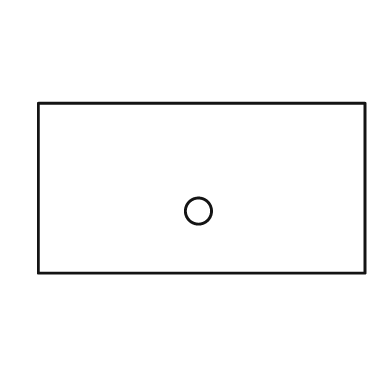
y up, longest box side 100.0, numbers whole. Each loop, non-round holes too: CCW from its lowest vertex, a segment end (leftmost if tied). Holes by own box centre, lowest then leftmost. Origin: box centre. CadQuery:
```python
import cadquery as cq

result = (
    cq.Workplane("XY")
    .moveTo(-50.0, -26.0)
    .lineTo(50.0, -26.0)
    .lineTo(50.0, 26.0)
    .lineTo(-50.0, 26.0)
    .close()
    .moveTo(-1.0, -7.0)
    .circle(4.0)
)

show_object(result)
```